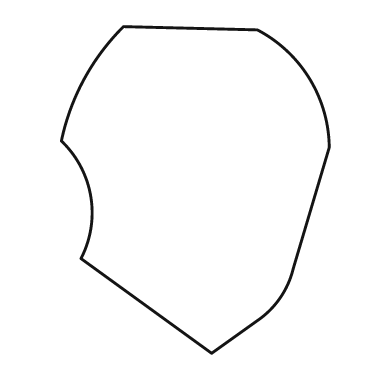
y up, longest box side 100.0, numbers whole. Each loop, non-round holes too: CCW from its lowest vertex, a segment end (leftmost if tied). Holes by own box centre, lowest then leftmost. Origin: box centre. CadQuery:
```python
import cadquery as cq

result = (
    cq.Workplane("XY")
    .moveTo(5.0, -50.0)
    .lineTo(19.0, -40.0)
    .threePointArc((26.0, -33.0), (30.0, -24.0))
    .lineTo(41.0, 13.0)
    .threePointArc((35.0, 34.0), (19.0, 49.0))
    .lineTo(-22.0, 50.0)
    .threePointArc((-34.0, 34.0), (-41.0, 15.0))
    .threePointArc((-32.0, -2.0), (-35.0, -21.0))
    .close()
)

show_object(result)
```